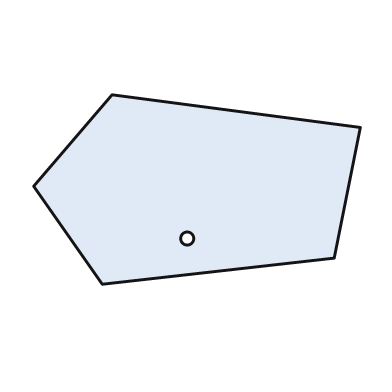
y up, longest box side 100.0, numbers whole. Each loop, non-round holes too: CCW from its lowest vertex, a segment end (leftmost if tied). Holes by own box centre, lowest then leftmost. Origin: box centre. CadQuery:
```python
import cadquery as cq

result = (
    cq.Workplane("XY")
    .moveTo(-29.0, -29.0)
    .lineTo(42.0, -21.0)
    .lineTo(50.0, 19.0)
    .lineTo(-26.0, 29.0)
    .lineTo(-50.0, 1.0)
    .close()
    .moveTo(-3.0, -15.0)
    .circle(2.0)
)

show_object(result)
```